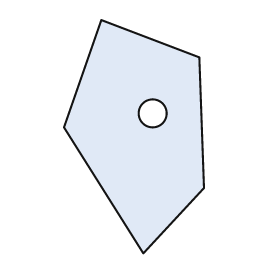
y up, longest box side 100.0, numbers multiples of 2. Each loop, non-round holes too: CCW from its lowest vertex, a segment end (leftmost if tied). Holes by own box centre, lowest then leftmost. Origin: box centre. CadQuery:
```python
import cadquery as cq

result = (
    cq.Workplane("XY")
    .moveTo(4.0, -50.0)
    .lineTo(30.0, -22.0)
    .lineTo(28.0, 34.0)
    .lineTo(-14.0, 50.0)
    .lineTo(-30.0, 4.0)
    .close()
    .moveTo(8.0, 10.0)
    .circle(6.0)
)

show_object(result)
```